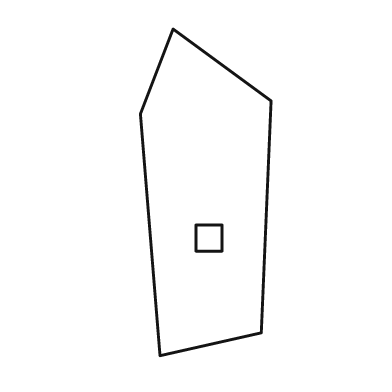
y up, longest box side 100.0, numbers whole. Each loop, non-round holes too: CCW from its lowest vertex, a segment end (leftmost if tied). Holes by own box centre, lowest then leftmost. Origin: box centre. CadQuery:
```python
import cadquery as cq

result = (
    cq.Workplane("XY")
    .moveTo(-14.0, -50.0)
    .lineTo(17.0, -43.0)
    .lineTo(20.0, 28.0)
    .lineTo(-10.0, 50.0)
    .lineTo(-20.0, 24.0)
    .close()
    .moveTo(-3.0, -18.0)
    .lineTo(5.0, -18.0)
    .lineTo(5.0, -10.0)
    .lineTo(-3.0, -10.0)
    .close()
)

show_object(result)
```